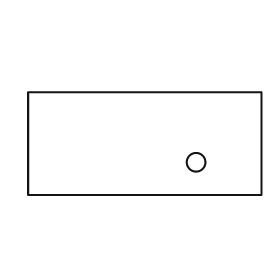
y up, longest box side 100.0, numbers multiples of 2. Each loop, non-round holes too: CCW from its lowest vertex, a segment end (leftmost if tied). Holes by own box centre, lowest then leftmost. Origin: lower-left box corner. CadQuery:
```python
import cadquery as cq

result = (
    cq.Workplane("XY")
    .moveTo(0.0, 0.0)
    .lineTo(100.0, 0.0)
    .lineTo(100.0, 44.0)
    .lineTo(0.0, 44.0)
    .close()
    .moveTo(72.0, 14.0)
    .circle(4.0)
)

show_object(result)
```